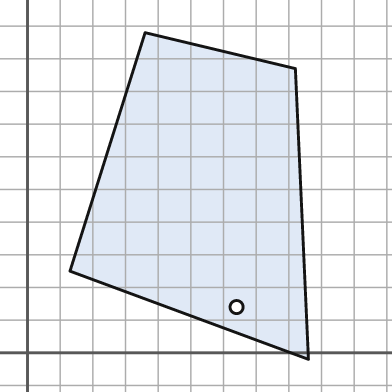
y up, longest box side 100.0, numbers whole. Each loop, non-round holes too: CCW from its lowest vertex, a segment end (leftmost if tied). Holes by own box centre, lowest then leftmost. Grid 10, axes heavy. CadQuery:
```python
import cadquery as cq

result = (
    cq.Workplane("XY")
    .moveTo(86.0, -2.0)
    .lineTo(82.0, 87.0)
    .lineTo(36.0, 98.0)
    .lineTo(13.0, 25.0)
    .close()
    .moveTo(64.0, 14.0)
    .circle(2.0)
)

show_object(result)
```